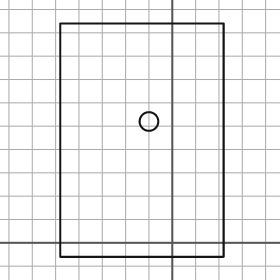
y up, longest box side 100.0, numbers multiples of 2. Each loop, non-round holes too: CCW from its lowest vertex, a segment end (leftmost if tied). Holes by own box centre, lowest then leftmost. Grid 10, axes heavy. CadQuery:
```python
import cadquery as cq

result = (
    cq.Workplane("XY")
    .moveTo(-48.0, -6.0)
    .lineTo(22.0, -6.0)
    .lineTo(22.0, 94.0)
    .lineTo(-48.0, 94.0)
    .close()
    .moveTo(-10.0, 52.0)
    .circle(4.0)
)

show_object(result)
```